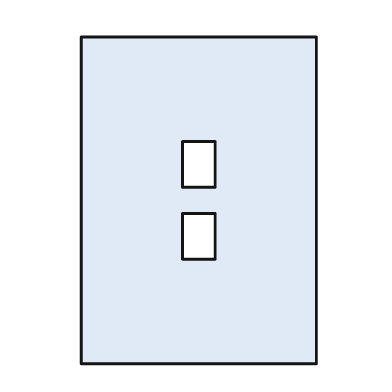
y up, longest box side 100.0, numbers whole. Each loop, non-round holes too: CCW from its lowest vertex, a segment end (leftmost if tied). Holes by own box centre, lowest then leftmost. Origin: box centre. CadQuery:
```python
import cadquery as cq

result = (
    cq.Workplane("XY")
    .moveTo(-36.0, -50.0)
    .lineTo(36.0, -50.0)
    .lineTo(36.0, 50.0)
    .lineTo(-36.0, 50.0)
    .close()
    .moveTo(-5.0, -18.0)
    .lineTo(5.0, -18.0)
    .lineTo(5.0, -4.0)
    .lineTo(-5.0, -4.0)
    .close()
    .moveTo(-5.0, 4.0)
    .lineTo(5.0, 4.0)
    .lineTo(5.0, 18.0)
    .lineTo(-5.0, 18.0)
    .close()
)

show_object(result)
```